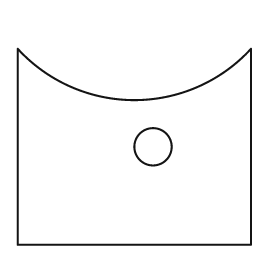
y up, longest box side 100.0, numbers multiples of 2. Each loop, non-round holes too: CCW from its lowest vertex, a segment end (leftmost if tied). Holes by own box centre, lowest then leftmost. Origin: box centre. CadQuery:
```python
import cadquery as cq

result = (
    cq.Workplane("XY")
    .moveTo(-50.0, -42.0)
    .lineTo(50.0, -42.0)
    .lineTo(50.0, 42.0)
    .threePointArc((0.0, 20.0), (-50.0, 42.0))
    .close()
    .moveTo(8.0, 0.0)
    .circle(8.0)
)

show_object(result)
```